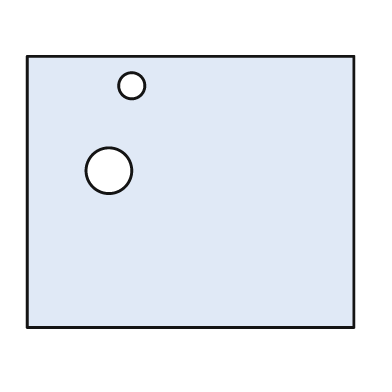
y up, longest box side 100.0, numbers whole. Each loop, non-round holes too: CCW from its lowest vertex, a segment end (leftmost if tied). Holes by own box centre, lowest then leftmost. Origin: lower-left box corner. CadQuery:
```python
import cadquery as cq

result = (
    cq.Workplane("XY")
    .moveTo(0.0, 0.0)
    .lineTo(100.0, 0.0)
    .lineTo(100.0, 83.0)
    .lineTo(0.0, 83.0)
    .close()
    .moveTo(25.0, 48.0)
    .circle(7.0)
    .moveTo(32.0, 74.0)
    .circle(4.0)
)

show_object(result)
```